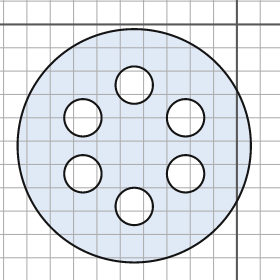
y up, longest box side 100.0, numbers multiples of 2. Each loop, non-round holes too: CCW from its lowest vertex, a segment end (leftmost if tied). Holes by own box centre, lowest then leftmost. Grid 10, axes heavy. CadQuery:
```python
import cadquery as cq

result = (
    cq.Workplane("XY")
    .moveTo(-44.0, -52.0)
    .circle(50.0)
    .moveTo(-44.0, -78.0)
    .circle(8.0)
    .moveTo(-66.0, -64.0)
    .circle(8.0)
    .moveTo(-22.0, -64.0)
    .circle(8.0)
    .moveTo(-66.0, -40.0)
    .circle(8.0)
    .moveTo(-22.0, -40.0)
    .circle(8.0)
    .moveTo(-44.0, -26.0)
    .circle(8.0)
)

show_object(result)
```